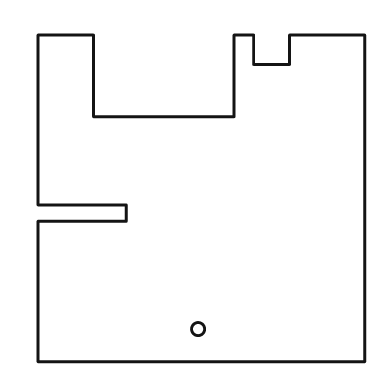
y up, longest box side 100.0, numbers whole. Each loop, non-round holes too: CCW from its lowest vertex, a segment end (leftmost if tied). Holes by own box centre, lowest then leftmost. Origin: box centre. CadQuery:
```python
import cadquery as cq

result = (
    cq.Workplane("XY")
    .moveTo(-50.0, -50.0)
    .lineTo(50.0, -50.0)
    .lineTo(50.0, 50.0)
    .lineTo(27.0, 50.0)
    .lineTo(27.0, 41.0)
    .lineTo(16.0, 41.0)
    .lineTo(16.0, 50.0)
    .lineTo(10.0, 50.0)
    .lineTo(10.0, 25.0)
    .lineTo(-33.0, 25.0)
    .lineTo(-33.0, 50.0)
    .lineTo(-50.0, 50.0)
    .lineTo(-50.0, -2.0)
    .lineTo(-23.0, -2.0)
    .lineTo(-23.0, -7.0)
    .lineTo(-50.0, -7.0)
    .close()
    .moveTo(-1.0, -40.0)
    .circle(2.0)
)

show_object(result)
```